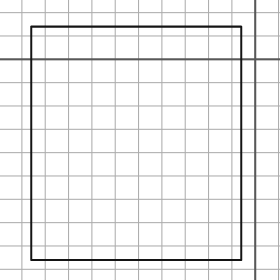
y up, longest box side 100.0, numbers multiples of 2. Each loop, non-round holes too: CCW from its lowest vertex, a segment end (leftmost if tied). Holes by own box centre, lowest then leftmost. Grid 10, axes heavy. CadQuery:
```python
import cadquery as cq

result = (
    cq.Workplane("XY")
    .moveTo(-96.0, -86.0)
    .lineTo(-6.0, -86.0)
    .lineTo(-6.0, 14.0)
    .lineTo(-96.0, 14.0)
    .close()
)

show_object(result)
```